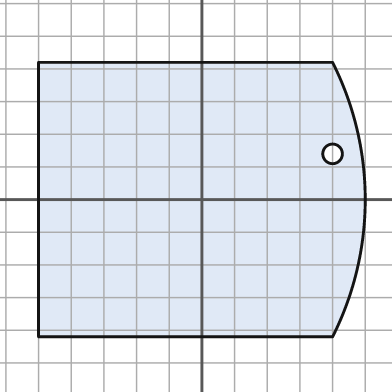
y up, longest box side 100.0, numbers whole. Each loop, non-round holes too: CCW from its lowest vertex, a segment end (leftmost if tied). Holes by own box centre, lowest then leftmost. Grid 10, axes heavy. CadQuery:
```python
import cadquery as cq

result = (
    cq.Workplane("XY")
    .moveTo(-50.0, -42.0)
    .lineTo(40.0, -42.0)
    .threePointArc((50.0, 0.0), (40.0, 42.0))
    .lineTo(-50.0, 42.0)
    .close()
    .moveTo(40.0, 14.0)
    .circle(3.0)
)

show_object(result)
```